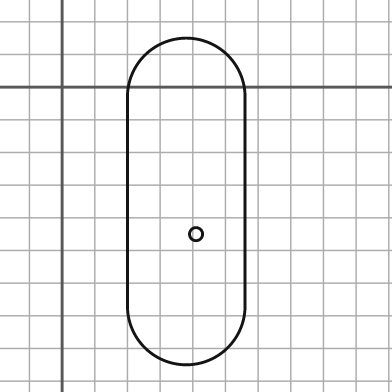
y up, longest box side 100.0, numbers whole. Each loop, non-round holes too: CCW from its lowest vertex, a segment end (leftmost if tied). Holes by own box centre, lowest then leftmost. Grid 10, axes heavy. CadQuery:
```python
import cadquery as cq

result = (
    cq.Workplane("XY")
    .moveTo(20.0, -67.0)
    .threePointArc((38.0, -85.0), (56.0, -67.0))
    .lineTo(56.0, -3.0)
    .threePointArc((38.0, 15.0), (20.0, -3.0))
    .close()
    .moveTo(41.0, -45.0)
    .circle(2.0)
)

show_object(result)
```